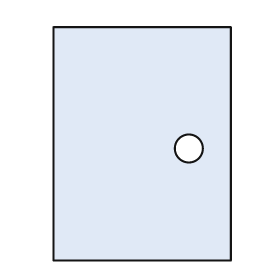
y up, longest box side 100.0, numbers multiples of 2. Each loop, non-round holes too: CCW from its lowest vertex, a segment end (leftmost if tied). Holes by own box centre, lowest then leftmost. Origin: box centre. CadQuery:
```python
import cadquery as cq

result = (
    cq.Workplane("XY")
    .moveTo(-38.0, -50.0)
    .lineTo(38.0, -50.0)
    .lineTo(38.0, 50.0)
    .lineTo(-38.0, 50.0)
    .close()
    .moveTo(20.0, -2.0)
    .circle(6.0)
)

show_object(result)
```